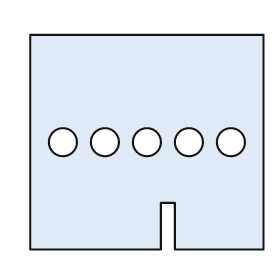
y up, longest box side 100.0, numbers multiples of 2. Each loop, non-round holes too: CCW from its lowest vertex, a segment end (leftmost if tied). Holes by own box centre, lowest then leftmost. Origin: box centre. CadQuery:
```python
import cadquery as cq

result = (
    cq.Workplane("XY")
    .moveTo(-50.0, -46.0)
    .lineTo(6.0, -46.0)
    .lineTo(6.0, -26.0)
    .lineTo(12.0, -26.0)
    .lineTo(12.0, -46.0)
    .lineTo(50.0, -46.0)
    .lineTo(50.0, 46.0)
    .lineTo(-50.0, 46.0)
    .close()
    .moveTo(-36.0, 0.0)
    .circle(6.0)
    .moveTo(-18.0, 0.0)
    .circle(6.0)
    .moveTo(0.0, 0.0)
    .circle(6.0)
    .moveTo(18.0, 0.0)
    .circle(6.0)
    .moveTo(36.0, 0.0)
    .circle(6.0)
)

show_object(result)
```